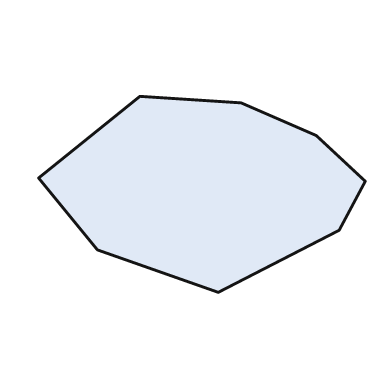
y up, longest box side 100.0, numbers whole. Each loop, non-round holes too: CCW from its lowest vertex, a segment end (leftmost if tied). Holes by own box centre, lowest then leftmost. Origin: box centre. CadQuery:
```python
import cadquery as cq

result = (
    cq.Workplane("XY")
    .moveTo(5.0, -30.0)
    .lineTo(42.0, -11.0)
    .lineTo(50.0, 4.0)
    .lineTo(35.0, 18.0)
    .lineTo(12.0, 28.0)
    .lineTo(-19.0, 30.0)
    .lineTo(-50.0, 5.0)
    .lineTo(-32.0, -17.0)
    .close()
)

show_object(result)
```